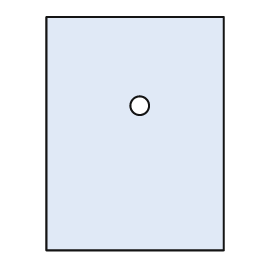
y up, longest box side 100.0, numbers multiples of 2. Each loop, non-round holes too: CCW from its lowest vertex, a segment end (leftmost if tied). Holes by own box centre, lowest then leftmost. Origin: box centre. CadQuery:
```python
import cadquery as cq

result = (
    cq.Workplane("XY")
    .moveTo(-38.0, -50.0)
    .lineTo(38.0, -50.0)
    .lineTo(38.0, 50.0)
    .lineTo(-38.0, 50.0)
    .close()
    .moveTo(2.0, 12.0)
    .circle(4.0)
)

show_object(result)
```